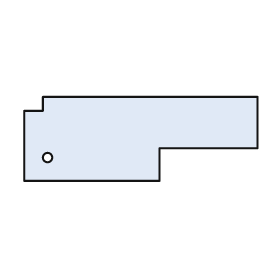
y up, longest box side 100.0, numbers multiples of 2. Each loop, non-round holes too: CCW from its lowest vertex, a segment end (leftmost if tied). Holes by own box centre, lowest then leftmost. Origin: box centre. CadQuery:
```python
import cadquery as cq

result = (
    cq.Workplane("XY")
    .moveTo(-50.0, -18.0)
    .lineTo(8.0, -18.0)
    .lineTo(8.0, -4.0)
    .lineTo(50.0, -4.0)
    .lineTo(50.0, 18.0)
    .lineTo(-42.0, 18.0)
    .lineTo(-42.0, 12.0)
    .lineTo(-50.0, 12.0)
    .close()
    .moveTo(-40.0, -8.0)
    .circle(2.0)
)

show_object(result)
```